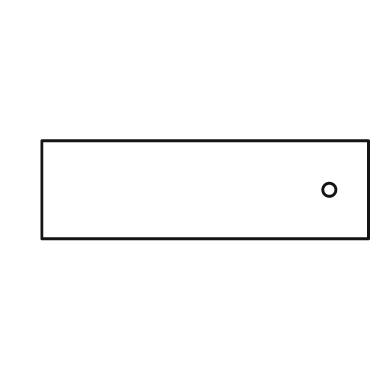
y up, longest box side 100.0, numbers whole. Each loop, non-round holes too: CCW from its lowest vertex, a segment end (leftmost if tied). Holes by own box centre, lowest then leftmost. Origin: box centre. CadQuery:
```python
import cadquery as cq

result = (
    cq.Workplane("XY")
    .moveTo(-50.0, -15.0)
    .lineTo(50.0, -15.0)
    .lineTo(50.0, 15.0)
    .lineTo(-50.0, 15.0)
    .close()
    .moveTo(38.0, 0.0)
    .circle(2.0)
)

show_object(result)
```